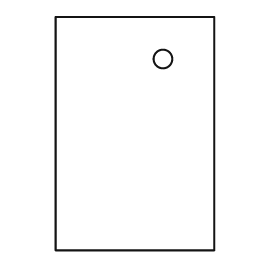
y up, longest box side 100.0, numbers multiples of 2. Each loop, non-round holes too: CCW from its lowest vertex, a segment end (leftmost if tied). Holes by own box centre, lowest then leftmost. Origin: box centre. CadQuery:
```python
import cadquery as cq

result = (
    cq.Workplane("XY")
    .moveTo(-34.0, -50.0)
    .lineTo(34.0, -50.0)
    .lineTo(34.0, 50.0)
    .lineTo(-34.0, 50.0)
    .close()
    .moveTo(12.0, 32.0)
    .circle(4.0)
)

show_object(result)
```